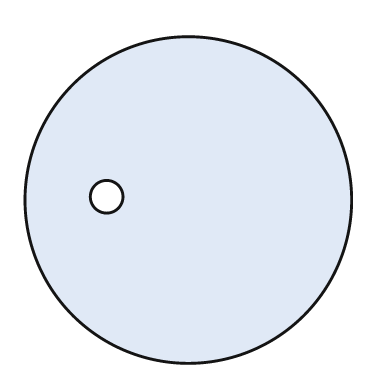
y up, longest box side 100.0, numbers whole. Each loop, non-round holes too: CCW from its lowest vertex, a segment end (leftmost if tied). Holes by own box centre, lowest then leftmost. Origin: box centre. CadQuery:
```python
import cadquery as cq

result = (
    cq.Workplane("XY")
    .moveTo(0.0, 0.0)
    .circle(50.0)
    .moveTo(-25.0, 1.0)
    .circle(5.0)
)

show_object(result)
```